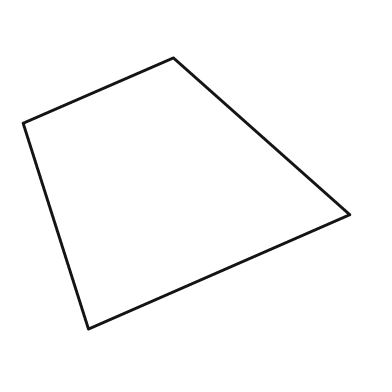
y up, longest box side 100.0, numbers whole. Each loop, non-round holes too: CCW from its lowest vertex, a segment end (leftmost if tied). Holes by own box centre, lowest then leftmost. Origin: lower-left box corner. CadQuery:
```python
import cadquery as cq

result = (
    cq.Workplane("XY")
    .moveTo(20.0, 0.0)
    .lineTo(100.0, 35.0)
    .lineTo(46.0, 83.0)
    .lineTo(0.0, 63.0)
    .close()
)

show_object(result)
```